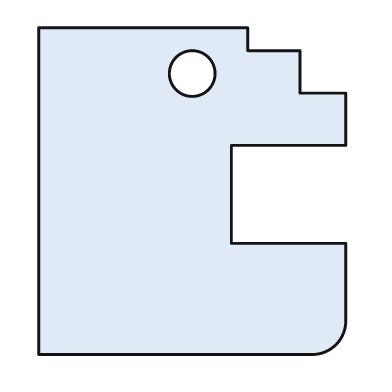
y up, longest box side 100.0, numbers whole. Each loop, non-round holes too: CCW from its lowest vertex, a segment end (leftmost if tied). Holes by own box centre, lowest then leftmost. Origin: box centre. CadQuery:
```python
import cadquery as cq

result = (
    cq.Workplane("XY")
    .moveTo(-47.0, -50.0)
    .lineTo(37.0, -50.0)
    .threePointArc((44.0, -47.0), (47.0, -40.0))
    .lineTo(47.0, -16.0)
    .lineTo(12.0, -16.0)
    .lineTo(12.0, 14.0)
    .lineTo(47.0, 14.0)
    .lineTo(47.0, 30.0)
    .lineTo(33.0, 30.0)
    .lineTo(33.0, 43.0)
    .lineTo(17.0, 43.0)
    .lineTo(17.0, 50.0)
    .lineTo(-47.0, 50.0)
    .close()
    .moveTo(0.0, 36.0)
    .circle(7.0)
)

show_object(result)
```